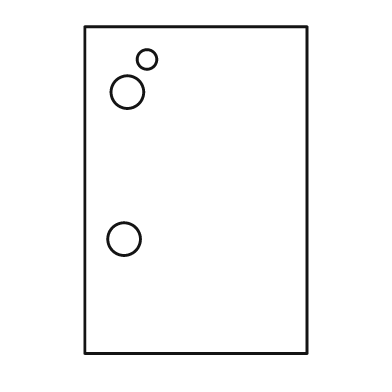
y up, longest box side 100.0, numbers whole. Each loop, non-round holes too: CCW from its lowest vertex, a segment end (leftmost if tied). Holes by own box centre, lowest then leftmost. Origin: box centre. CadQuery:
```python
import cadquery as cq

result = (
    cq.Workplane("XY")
    .moveTo(-34.0, -50.0)
    .lineTo(34.0, -50.0)
    .lineTo(34.0, 50.0)
    .lineTo(-34.0, 50.0)
    .close()
    .moveTo(-22.0, -15.0)
    .circle(5.0)
    .moveTo(-21.0, 30.0)
    .circle(5.0)
    .moveTo(-15.0, 40.0)
    .circle(3.0)
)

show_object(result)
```